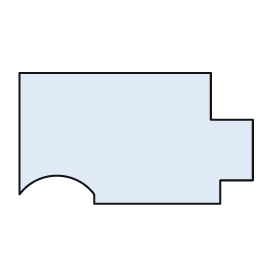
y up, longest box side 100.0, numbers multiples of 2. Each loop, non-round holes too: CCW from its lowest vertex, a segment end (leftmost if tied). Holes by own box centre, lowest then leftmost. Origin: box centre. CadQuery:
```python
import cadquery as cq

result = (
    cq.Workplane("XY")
    .moveTo(-18.0, -28.0)
    .lineTo(36.0, -28.0)
    .lineTo(36.0, -18.0)
    .lineTo(50.0, -18.0)
    .lineTo(50.0, 8.0)
    .lineTo(32.0, 8.0)
    .lineTo(32.0, 28.0)
    .lineTo(-50.0, 28.0)
    .lineTo(-50.0, -24.0)
    .threePointArc((-34.0, -16.0), (-18.0, -24.0))
    .close()
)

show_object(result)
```